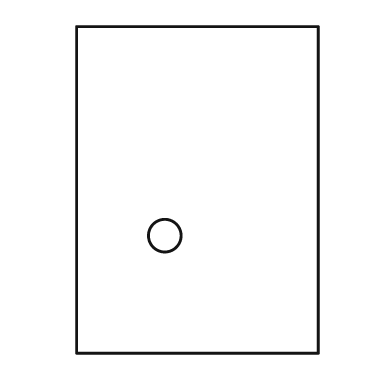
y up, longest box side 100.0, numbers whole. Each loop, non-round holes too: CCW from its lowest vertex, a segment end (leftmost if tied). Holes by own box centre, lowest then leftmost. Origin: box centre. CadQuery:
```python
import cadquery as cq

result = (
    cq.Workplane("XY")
    .moveTo(-37.0, -50.0)
    .lineTo(37.0, -50.0)
    .lineTo(37.0, 50.0)
    .lineTo(-37.0, 50.0)
    .close()
    .moveTo(-10.0, -14.0)
    .circle(5.0)
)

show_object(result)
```